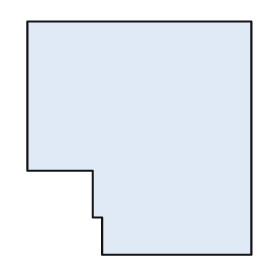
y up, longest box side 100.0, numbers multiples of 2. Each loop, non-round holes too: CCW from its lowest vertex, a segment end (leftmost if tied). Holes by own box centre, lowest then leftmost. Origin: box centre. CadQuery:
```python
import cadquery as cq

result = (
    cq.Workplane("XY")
    .moveTo(-16.0, -50.0)
    .lineTo(48.0, -50.0)
    .lineTo(48.0, 50.0)
    .lineTo(-48.0, 50.0)
    .lineTo(-48.0, -14.0)
    .lineTo(-20.0, -14.0)
    .lineTo(-20.0, -34.0)
    .lineTo(-16.0, -34.0)
    .close()
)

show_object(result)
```